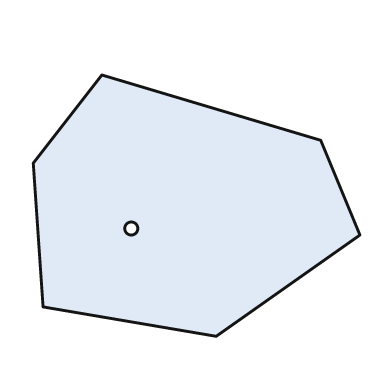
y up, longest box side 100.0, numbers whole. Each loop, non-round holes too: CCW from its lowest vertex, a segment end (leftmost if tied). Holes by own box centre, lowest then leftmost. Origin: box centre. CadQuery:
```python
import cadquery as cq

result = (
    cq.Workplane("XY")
    .moveTo(6.0, -40.0)
    .lineTo(50.0, -9.0)
    .lineTo(38.0, 20.0)
    .lineTo(-29.0, 40.0)
    .lineTo(-50.0, 13.0)
    .lineTo(-47.0, -31.0)
    .close()
    .moveTo(-20.0, -7.0)
    .circle(2.0)
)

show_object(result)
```